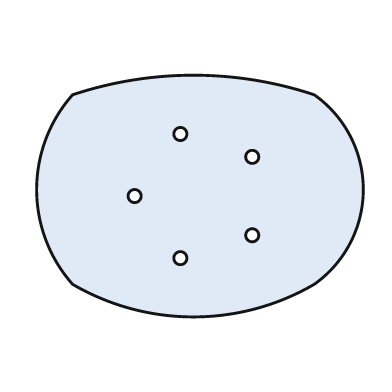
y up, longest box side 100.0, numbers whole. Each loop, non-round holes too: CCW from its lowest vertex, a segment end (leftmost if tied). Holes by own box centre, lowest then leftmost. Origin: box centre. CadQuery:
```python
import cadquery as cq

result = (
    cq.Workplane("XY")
    .moveTo(-39.0, -27.0)
    .threePointArc((-2.0, -37.0), (35.0, -27.0))
    .threePointArc((50.0, 2.0), (35.0, 31.0))
    .threePointArc((-2.0, 37.0), (-39.0, 31.0))
    .threePointArc((-50.0, 2.0), (-39.0, -27.0))
    .close()
    .moveTo(-6.0, -19.0)
    .circle(2.0)
    .moveTo(16.0, -12.0)
    .circle(2.0)
    .moveTo(-20.0, 0.0)
    .circle(2.0)
    .moveTo(16.0, 12.0)
    .circle(2.0)
    .moveTo(-6.0, 19.0)
    .circle(2.0)
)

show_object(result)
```